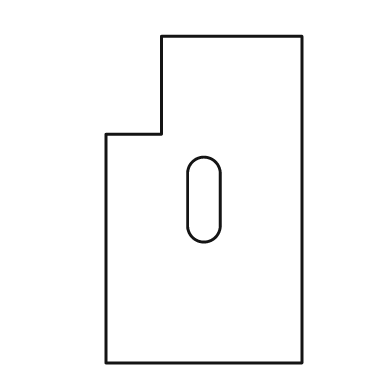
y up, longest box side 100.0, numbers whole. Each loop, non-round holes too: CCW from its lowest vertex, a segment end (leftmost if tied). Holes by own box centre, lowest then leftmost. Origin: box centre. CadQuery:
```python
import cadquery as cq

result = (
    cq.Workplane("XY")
    .moveTo(-30.0, -50.0)
    .lineTo(30.0, -50.0)
    .lineTo(30.0, 50.0)
    .lineTo(-13.0, 50.0)
    .lineTo(-13.0, 20.0)
    .lineTo(-30.0, 20.0)
    .close()
    .moveTo(-5.0, -8.0)
    .threePointArc((0.0, -13.0), (5.0, -8.0))
    .lineTo(5.0, 8.0)
    .threePointArc((0.0, 13.0), (-5.0, 8.0))
    .close()
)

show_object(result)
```